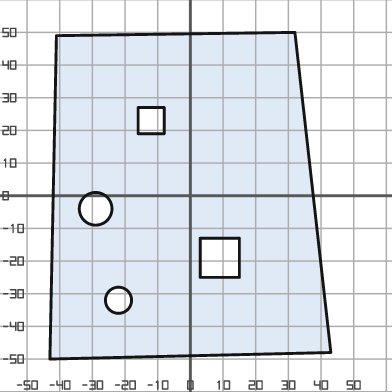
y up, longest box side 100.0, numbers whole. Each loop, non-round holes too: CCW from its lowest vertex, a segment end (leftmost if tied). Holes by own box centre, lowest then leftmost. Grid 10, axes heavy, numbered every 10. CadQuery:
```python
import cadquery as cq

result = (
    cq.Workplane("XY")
    .moveTo(-43.0, -50.0)
    .lineTo(43.0, -48.0)
    .lineTo(32.0, 50.0)
    .lineTo(-41.0, 49.0)
    .close()
    .moveTo(-22.0, -32.0)
    .circle(4.0)
    .moveTo(3.0, -25.0)
    .lineTo(15.0, -25.0)
    .lineTo(15.0, -13.0)
    .lineTo(3.0, -13.0)
    .close()
    .moveTo(-29.0, -4.0)
    .circle(5.0)
    .moveTo(-16.0, 19.0)
    .lineTo(-8.0, 19.0)
    .lineTo(-8.0, 27.0)
    .lineTo(-16.0, 27.0)
    .close()
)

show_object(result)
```